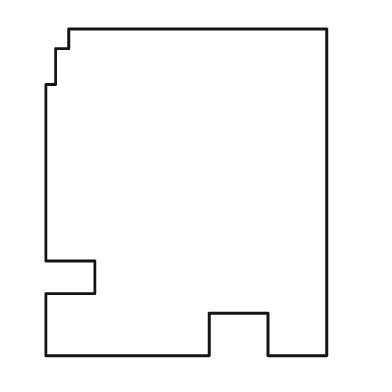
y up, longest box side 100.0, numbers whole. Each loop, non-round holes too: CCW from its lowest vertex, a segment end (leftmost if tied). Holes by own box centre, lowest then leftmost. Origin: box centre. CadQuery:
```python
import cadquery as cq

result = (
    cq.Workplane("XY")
    .moveTo(-43.0, -50.0)
    .lineTo(7.0, -50.0)
    .lineTo(7.0, -37.0)
    .lineTo(25.0, -37.0)
    .lineTo(25.0, -50.0)
    .lineTo(43.0, -50.0)
    .lineTo(43.0, 50.0)
    .lineTo(-36.0, 50.0)
    .lineTo(-36.0, 44.0)
    .lineTo(-40.0, 44.0)
    .lineTo(-40.0, 33.0)
    .lineTo(-43.0, 33.0)
    .lineTo(-43.0, -21.0)
    .lineTo(-28.0, -21.0)
    .lineTo(-28.0, -31.0)
    .lineTo(-43.0, -31.0)
    .close()
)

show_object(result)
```